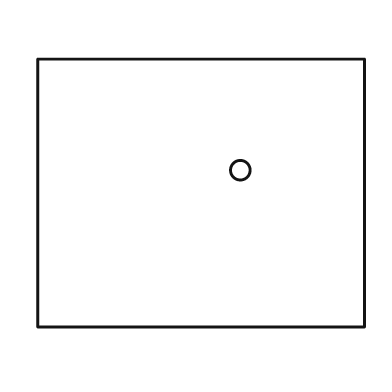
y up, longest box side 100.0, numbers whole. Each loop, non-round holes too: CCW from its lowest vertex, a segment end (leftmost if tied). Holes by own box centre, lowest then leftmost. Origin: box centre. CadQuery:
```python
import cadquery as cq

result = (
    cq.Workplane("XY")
    .moveTo(-50.0, -41.0)
    .lineTo(50.0, -41.0)
    .lineTo(50.0, 41.0)
    .lineTo(-50.0, 41.0)
    .close()
    .moveTo(12.0, 7.0)
    .circle(3.0)
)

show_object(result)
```